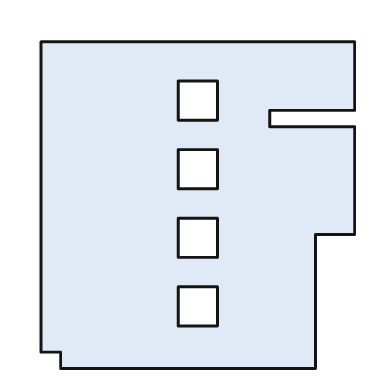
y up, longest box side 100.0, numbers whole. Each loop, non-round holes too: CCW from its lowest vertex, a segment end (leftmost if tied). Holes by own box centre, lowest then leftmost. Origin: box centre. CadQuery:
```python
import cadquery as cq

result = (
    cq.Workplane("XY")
    .moveTo(-42.0, -50.0)
    .lineTo(36.0, -50.0)
    .lineTo(36.0, -9.0)
    .lineTo(48.0, -9.0)
    .lineTo(48.0, 24.0)
    .lineTo(22.0, 24.0)
    .lineTo(22.0, 29.0)
    .lineTo(48.0, 29.0)
    .lineTo(48.0, 50.0)
    .lineTo(-48.0, 50.0)
    .lineTo(-48.0, -45.0)
    .lineTo(-42.0, -45.0)
    .close()
    .moveTo(-6.0, -37.0)
    .lineTo(6.0, -37.0)
    .lineTo(6.0, -25.0)
    .lineTo(-6.0, -25.0)
    .close()
    .moveTo(-6.0, -16.0)
    .lineTo(6.0, -16.0)
    .lineTo(6.0, -4.0)
    .lineTo(-6.0, -4.0)
    .close()
    .moveTo(-6.0, 5.0)
    .lineTo(6.0, 5.0)
    .lineTo(6.0, 17.0)
    .lineTo(-6.0, 17.0)
    .close()
    .moveTo(-6.0, 26.0)
    .lineTo(6.0, 26.0)
    .lineTo(6.0, 38.0)
    .lineTo(-6.0, 38.0)
    .close()
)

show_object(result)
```